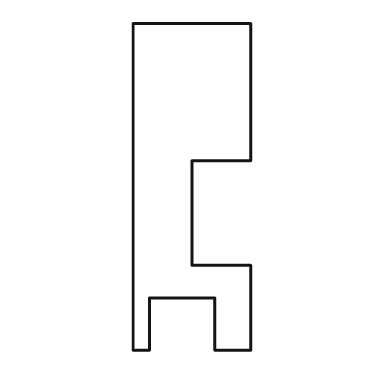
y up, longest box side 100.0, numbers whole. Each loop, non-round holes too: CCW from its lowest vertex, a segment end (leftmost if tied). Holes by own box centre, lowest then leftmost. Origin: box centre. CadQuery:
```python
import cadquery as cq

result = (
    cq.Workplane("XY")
    .moveTo(-18.0, -50.0)
    .lineTo(-13.0, -50.0)
    .lineTo(-13.0, -34.0)
    .lineTo(7.0, -34.0)
    .lineTo(7.0, -50.0)
    .lineTo(18.0, -50.0)
    .lineTo(18.0, -24.0)
    .lineTo(0.0, -24.0)
    .lineTo(0.0, 8.0)
    .lineTo(18.0, 8.0)
    .lineTo(18.0, 50.0)
    .lineTo(-18.0, 50.0)
    .close()
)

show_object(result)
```